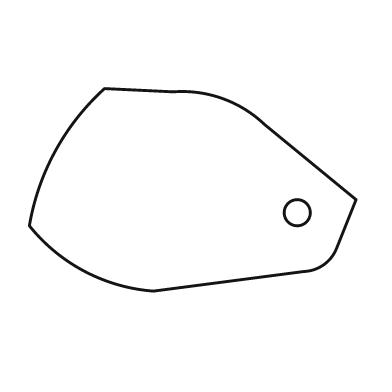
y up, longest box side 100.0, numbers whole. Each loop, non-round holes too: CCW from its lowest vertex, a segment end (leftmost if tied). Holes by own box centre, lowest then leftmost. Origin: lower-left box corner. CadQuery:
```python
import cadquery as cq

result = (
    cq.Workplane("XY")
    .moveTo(38.0, 0.0)
    .lineTo(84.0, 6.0)
    .threePointArc((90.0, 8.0), (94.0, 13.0))
    .lineTo(100.0, 28.0)
    .lineTo(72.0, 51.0)
    .threePointArc((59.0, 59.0), (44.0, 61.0))
    .lineTo(23.0, 62.0)
    .threePointArc((8.0, 43.0), (0.0, 20.0))
    .threePointArc((17.0, 6.0), (38.0, 0.0))
    .close()
    .moveTo(82.0, 24.0)
    .circle(4.0)
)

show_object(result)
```